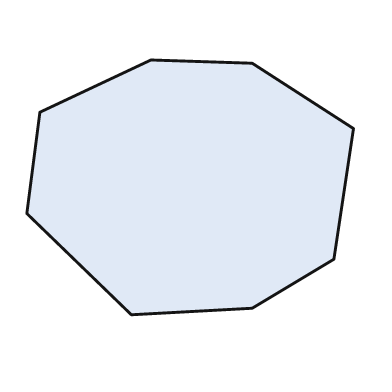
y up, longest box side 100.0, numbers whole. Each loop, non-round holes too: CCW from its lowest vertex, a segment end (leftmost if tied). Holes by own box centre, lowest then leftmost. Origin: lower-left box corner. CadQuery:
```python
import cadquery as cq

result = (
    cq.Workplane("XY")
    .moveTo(32.0, 0.0)
    .lineTo(69.0, 2.0)
    .lineTo(94.0, 17.0)
    .lineTo(100.0, 57.0)
    .lineTo(69.0, 77.0)
    .lineTo(38.0, 78.0)
    .lineTo(4.0, 62.0)
    .lineTo(0.0, 31.0)
    .close()
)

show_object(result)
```